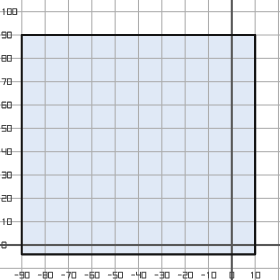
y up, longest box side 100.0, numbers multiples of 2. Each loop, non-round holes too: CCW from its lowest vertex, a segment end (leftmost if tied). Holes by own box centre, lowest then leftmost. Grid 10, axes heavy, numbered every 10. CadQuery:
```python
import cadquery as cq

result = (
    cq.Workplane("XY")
    .moveTo(-90.0, -4.0)
    .lineTo(10.0, -4.0)
    .lineTo(10.0, 90.0)
    .lineTo(-90.0, 90.0)
    .close()
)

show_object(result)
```